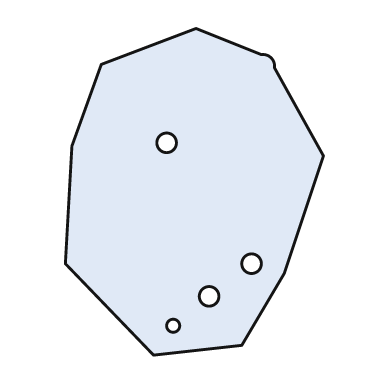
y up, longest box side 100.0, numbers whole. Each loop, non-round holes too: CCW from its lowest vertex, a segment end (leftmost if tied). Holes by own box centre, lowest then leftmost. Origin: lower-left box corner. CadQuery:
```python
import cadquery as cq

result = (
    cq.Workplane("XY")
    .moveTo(27.0, 0.0)
    .lineTo(54.0, 3.0)
    .lineTo(67.0, 25.0)
    .lineTo(79.0, 61.0)
    .lineTo(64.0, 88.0)
    .threePointArc((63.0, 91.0), (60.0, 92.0))
    .lineTo(40.0, 100.0)
    .lineTo(11.0, 89.0)
    .lineTo(2.0, 64.0)
    .lineTo(0.0, 28.0)
    .close()
    .moveTo(33.0, 9.0)
    .circle(2.0)
    .moveTo(44.0, 18.0)
    .circle(3.0)
    .moveTo(57.0, 28.0)
    .circle(3.0)
    .moveTo(31.0, 65.0)
    .circle(3.0)
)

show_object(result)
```